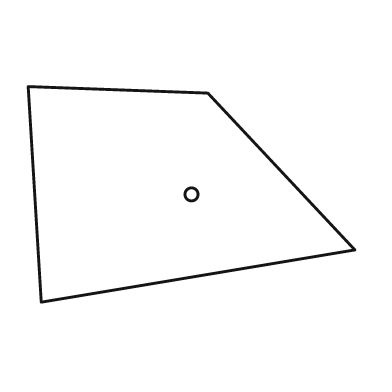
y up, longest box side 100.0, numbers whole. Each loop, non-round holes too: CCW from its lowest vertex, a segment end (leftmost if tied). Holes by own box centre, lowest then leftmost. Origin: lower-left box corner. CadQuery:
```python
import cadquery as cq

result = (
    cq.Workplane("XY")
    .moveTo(4.0, 0.0)
    .lineTo(100.0, 16.0)
    .lineTo(55.0, 64.0)
    .lineTo(0.0, 66.0)
    .close()
    .moveTo(50.0, 33.0)
    .circle(2.0)
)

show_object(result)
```